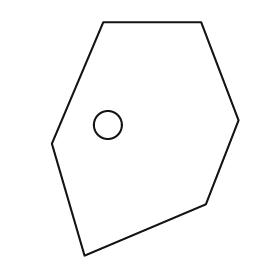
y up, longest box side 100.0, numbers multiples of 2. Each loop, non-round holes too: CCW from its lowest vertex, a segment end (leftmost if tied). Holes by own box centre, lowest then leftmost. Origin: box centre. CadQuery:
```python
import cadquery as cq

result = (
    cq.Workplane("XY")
    .moveTo(-26.0, -50.0)
    .lineTo(26.0, -28.0)
    .lineTo(40.0, 8.0)
    .lineTo(24.0, 50.0)
    .lineTo(-18.0, 50.0)
    .lineTo(-40.0, -2.0)
    .close()
    .moveTo(-16.0, 6.0)
    .circle(6.0)
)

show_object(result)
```